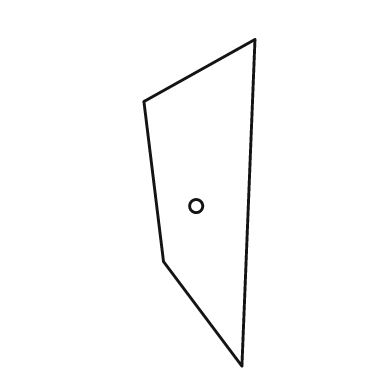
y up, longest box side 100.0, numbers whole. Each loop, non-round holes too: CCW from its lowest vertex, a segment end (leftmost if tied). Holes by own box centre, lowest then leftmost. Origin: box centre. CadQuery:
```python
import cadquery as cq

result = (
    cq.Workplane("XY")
    .moveTo(13.0, -50.0)
    .lineTo(17.0, 50.0)
    .lineTo(-17.0, 31.0)
    .lineTo(-11.0, -18.0)
    .close()
    .moveTo(-1.0, -1.0)
    .circle(2.0)
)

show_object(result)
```